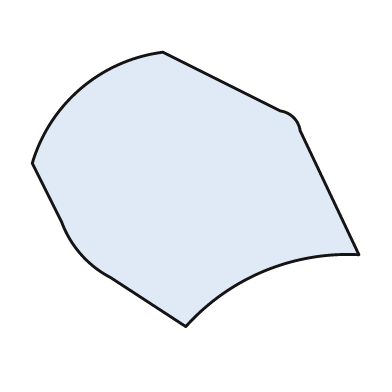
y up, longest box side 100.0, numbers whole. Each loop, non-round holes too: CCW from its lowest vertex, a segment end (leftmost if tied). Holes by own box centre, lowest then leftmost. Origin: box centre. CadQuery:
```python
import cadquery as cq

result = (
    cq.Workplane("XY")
    .moveTo(-3.0, -42.0)
    .threePointArc((21.0, -25.0), (50.0, -20.0))
    .lineTo(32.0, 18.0)
    .threePointArc((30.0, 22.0), (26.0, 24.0))
    .lineTo(-10.0, 42.0)
    .threePointArc((-35.0, 31.0), (-50.0, 8.0))
    .lineTo(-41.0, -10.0)
    .threePointArc((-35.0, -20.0), (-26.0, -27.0))
    .close()
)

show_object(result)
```